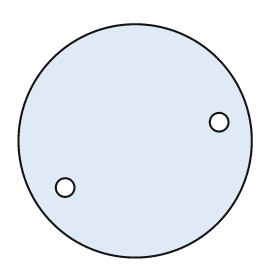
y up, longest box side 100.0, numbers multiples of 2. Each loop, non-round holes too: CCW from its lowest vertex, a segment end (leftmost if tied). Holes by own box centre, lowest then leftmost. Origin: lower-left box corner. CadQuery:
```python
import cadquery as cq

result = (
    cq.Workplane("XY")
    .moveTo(50.0, 50.0)
    .circle(50.0)
    .moveTo(20.0, 30.0)
    .circle(4.0)
    .moveTo(86.0, 58.0)
    .circle(4.0)
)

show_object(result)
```